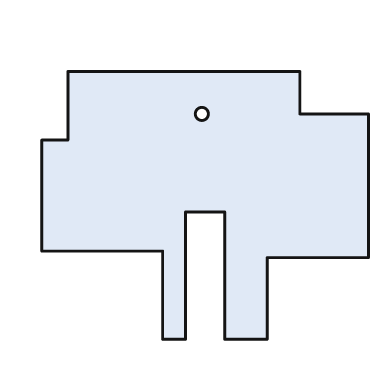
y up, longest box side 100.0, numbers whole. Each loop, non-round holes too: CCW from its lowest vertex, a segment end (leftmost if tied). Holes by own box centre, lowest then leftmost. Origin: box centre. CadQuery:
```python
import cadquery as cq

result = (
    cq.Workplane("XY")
    .moveTo(-13.0, -41.0)
    .lineTo(-6.0, -41.0)
    .lineTo(-6.0, -2.0)
    .lineTo(6.0, -2.0)
    .lineTo(6.0, -41.0)
    .lineTo(19.0, -41.0)
    .lineTo(19.0, -16.0)
    .lineTo(50.0, -16.0)
    .lineTo(50.0, 28.0)
    .lineTo(29.0, 28.0)
    .lineTo(29.0, 41.0)
    .lineTo(-42.0, 41.0)
    .lineTo(-42.0, 20.0)
    .lineTo(-50.0, 20.0)
    .lineTo(-50.0, -14.0)
    .lineTo(-13.0, -14.0)
    .close()
    .moveTo(-1.0, 28.0)
    .circle(2.0)
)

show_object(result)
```